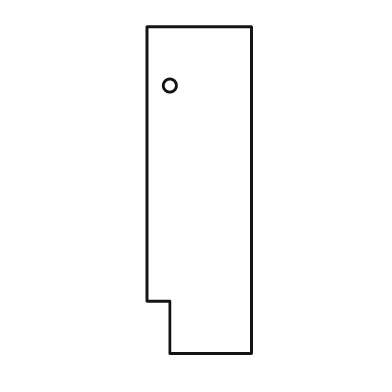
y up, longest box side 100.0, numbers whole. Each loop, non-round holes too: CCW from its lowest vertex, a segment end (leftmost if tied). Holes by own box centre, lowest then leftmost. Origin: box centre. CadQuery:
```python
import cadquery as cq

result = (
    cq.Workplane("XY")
    .moveTo(-9.0, -50.0)
    .lineTo(16.0, -50.0)
    .lineTo(16.0, 50.0)
    .lineTo(-16.0, 50.0)
    .lineTo(-16.0, -34.0)
    .lineTo(-9.0, -34.0)
    .close()
    .moveTo(-9.0, 32.0)
    .circle(2.0)
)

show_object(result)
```